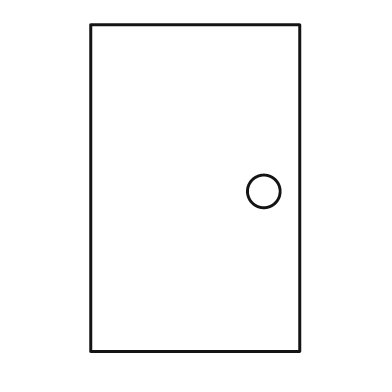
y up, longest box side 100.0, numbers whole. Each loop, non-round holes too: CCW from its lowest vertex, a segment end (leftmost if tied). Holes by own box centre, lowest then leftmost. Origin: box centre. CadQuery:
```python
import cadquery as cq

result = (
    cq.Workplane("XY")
    .moveTo(-32.0, -50.0)
    .lineTo(32.0, -50.0)
    .lineTo(32.0, 50.0)
    .lineTo(-32.0, 50.0)
    .close()
    .moveTo(21.0, -1.0)
    .circle(5.0)
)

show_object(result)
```